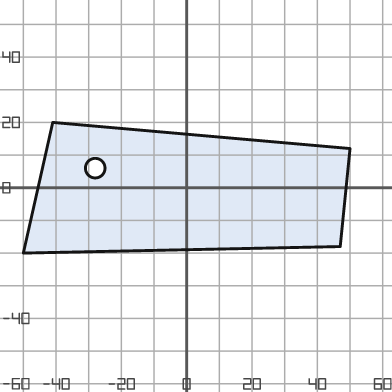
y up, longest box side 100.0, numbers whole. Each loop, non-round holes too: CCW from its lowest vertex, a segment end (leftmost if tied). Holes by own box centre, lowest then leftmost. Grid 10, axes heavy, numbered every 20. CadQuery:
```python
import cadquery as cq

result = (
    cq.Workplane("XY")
    .moveTo(-50.0, -20.0)
    .lineTo(47.0, -18.0)
    .lineTo(50.0, 12.0)
    .lineTo(-41.0, 20.0)
    .close()
    .moveTo(-28.0, 6.0)
    .circle(3.0)
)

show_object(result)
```